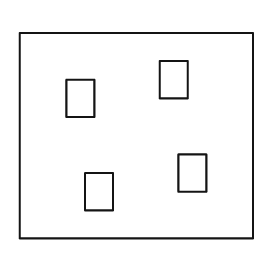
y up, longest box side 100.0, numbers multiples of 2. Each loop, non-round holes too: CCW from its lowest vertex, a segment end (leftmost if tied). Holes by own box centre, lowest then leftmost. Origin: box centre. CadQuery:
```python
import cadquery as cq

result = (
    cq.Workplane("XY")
    .moveTo(-50.0, -44.0)
    .lineTo(50.0, -44.0)
    .lineTo(50.0, 44.0)
    .lineTo(-50.0, 44.0)
    .close()
    .moveTo(-22.0, -32.0)
    .lineTo(-10.0, -32.0)
    .lineTo(-10.0, -16.0)
    .lineTo(-22.0, -16.0)
    .close()
    .moveTo(18.0, -24.0)
    .lineTo(30.0, -24.0)
    .lineTo(30.0, -8.0)
    .lineTo(18.0, -8.0)
    .close()
    .moveTo(-30.0, 8.0)
    .lineTo(-18.0, 8.0)
    .lineTo(-18.0, 24.0)
    .lineTo(-30.0, 24.0)
    .close()
    .moveTo(10.0, 16.0)
    .lineTo(22.0, 16.0)
    .lineTo(22.0, 32.0)
    .lineTo(10.0, 32.0)
    .close()
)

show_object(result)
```